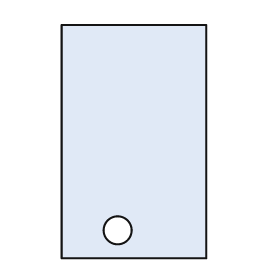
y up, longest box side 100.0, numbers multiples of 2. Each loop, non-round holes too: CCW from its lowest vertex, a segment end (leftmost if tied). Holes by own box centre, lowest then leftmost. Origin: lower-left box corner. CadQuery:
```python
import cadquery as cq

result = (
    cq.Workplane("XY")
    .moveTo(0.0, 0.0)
    .lineTo(62.0, 0.0)
    .lineTo(62.0, 100.0)
    .lineTo(0.0, 100.0)
    .close()
    .moveTo(24.0, 12.0)
    .circle(6.0)
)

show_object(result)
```